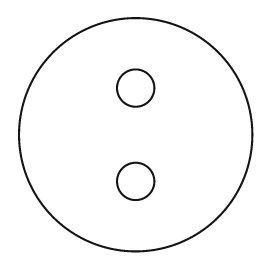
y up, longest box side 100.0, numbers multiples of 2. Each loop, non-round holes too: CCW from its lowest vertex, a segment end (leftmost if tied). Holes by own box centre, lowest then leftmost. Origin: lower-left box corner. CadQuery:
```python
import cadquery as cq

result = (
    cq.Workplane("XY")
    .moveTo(50.0, 50.0)
    .circle(50.0)
    .moveTo(50.0, 30.0)
    .circle(8.0)
    .moveTo(50.0, 70.0)
    .circle(8.0)
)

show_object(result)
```